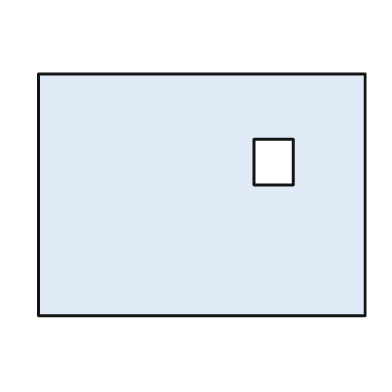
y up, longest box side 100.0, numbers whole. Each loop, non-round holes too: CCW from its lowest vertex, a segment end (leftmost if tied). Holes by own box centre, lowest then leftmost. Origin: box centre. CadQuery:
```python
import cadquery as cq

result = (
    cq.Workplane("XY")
    .moveTo(-50.0, -37.0)
    .lineTo(50.0, -37.0)
    .lineTo(50.0, 37.0)
    .lineTo(-50.0, 37.0)
    .close()
    .moveTo(16.0, 3.0)
    .lineTo(28.0, 3.0)
    .lineTo(28.0, 17.0)
    .lineTo(16.0, 17.0)
    .close()
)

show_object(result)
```